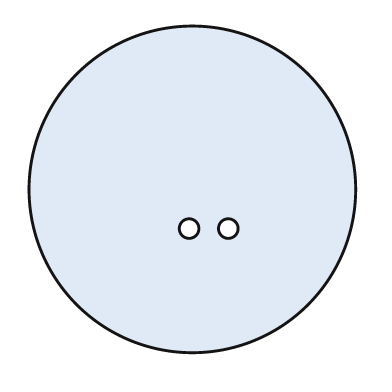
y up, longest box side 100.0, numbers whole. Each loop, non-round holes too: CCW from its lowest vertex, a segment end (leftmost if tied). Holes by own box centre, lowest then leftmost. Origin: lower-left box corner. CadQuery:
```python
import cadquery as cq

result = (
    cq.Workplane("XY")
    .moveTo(50.0, 50.0)
    .circle(50.0)
    .moveTo(49.0, 38.0)
    .circle(3.0)
    .moveTo(61.0, 38.0)
    .circle(3.0)
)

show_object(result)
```